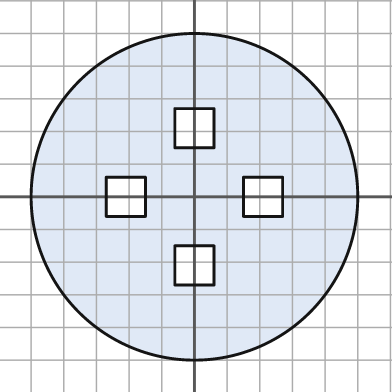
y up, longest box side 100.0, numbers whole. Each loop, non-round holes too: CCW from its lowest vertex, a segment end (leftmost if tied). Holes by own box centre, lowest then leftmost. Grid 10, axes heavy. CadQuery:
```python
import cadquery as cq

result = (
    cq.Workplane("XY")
    .moveTo(0.0, 0.0)
    .circle(50.0)
    .moveTo(-6.0, -27.0)
    .lineTo(6.0, -27.0)
    .lineTo(6.0, -15.0)
    .lineTo(-6.0, -15.0)
    .close()
    .moveTo(-27.0, -6.0)
    .lineTo(-15.0, -6.0)
    .lineTo(-15.0, 6.0)
    .lineTo(-27.0, 6.0)
    .close()
    .moveTo(15.0, -6.0)
    .lineTo(27.0, -6.0)
    .lineTo(27.0, 6.0)
    .lineTo(15.0, 6.0)
    .close()
    .moveTo(-6.0, 15.0)
    .lineTo(6.0, 15.0)
    .lineTo(6.0, 27.0)
    .lineTo(-6.0, 27.0)
    .close()
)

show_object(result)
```